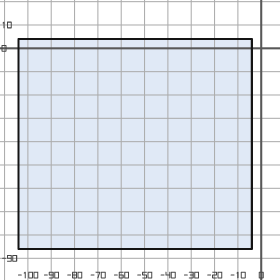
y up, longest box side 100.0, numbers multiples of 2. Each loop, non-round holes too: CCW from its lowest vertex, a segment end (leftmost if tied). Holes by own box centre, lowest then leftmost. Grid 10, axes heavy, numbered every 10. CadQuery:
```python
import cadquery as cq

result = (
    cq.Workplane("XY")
    .moveTo(-104.0, -86.0)
    .lineTo(-4.0, -86.0)
    .lineTo(-4.0, 4.0)
    .lineTo(-104.0, 4.0)
    .close()
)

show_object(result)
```